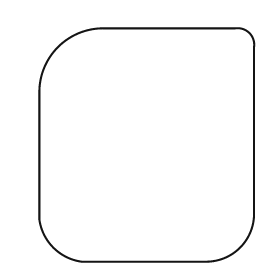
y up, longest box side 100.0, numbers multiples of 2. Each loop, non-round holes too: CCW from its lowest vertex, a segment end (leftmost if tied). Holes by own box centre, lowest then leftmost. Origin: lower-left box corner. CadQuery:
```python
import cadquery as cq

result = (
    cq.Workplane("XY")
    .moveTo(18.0, 0.0)
    .lineTo(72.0, 0.0)
    .threePointArc((86.0, 6.0), (92.0, 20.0))
    .lineTo(92.0, 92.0)
    .threePointArc((90.0, 98.0), (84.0, 100.0))
    .lineTo(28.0, 100.0)
    .threePointArc((8.0, 92.0), (0.0, 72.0))
    .lineTo(0.0, 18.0)
    .threePointArc((6.0, 6.0), (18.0, 0.0))
    .close()
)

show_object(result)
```